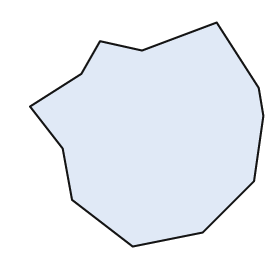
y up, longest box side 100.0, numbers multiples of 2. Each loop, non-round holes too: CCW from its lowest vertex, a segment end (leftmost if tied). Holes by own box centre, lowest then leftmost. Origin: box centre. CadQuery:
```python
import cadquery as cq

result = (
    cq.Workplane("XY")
    .moveTo(-6.0, -48.0)
    .lineTo(24.0, -42.0)
    .lineTo(46.0, -20.0)
    .lineTo(50.0, 8.0)
    .lineTo(48.0, 20.0)
    .lineTo(30.0, 48.0)
    .lineTo(-2.0, 36.0)
    .lineTo(-20.0, 40.0)
    .lineTo(-28.0, 26.0)
    .lineTo(-50.0, 12.0)
    .lineTo(-36.0, -6.0)
    .lineTo(-32.0, -28.0)
    .close()
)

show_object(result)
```